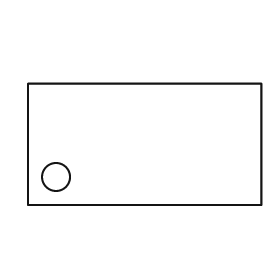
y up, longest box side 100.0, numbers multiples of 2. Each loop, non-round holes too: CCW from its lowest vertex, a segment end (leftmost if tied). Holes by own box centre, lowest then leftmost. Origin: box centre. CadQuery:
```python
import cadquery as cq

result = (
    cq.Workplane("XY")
    .moveTo(-50.0, -26.0)
    .lineTo(50.0, -26.0)
    .lineTo(50.0, 26.0)
    .lineTo(-50.0, 26.0)
    .close()
    .moveTo(-38.0, -14.0)
    .circle(6.0)
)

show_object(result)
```